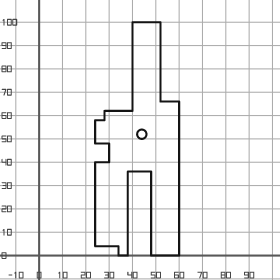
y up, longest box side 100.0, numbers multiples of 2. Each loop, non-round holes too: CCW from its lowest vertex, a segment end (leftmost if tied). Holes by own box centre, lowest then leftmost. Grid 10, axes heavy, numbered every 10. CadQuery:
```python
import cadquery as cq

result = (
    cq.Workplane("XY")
    .moveTo(34.0, 0.0)
    .lineTo(38.0, 0.0)
    .lineTo(38.0, 36.0)
    .lineTo(48.0, 36.0)
    .lineTo(48.0, 0.0)
    .lineTo(60.0, 0.0)
    .lineTo(60.0, 66.0)
    .lineTo(52.0, 66.0)
    .lineTo(52.0, 100.0)
    .lineTo(40.0, 100.0)
    .lineTo(40.0, 62.0)
    .lineTo(28.0, 62.0)
    .lineTo(28.0, 58.0)
    .lineTo(24.0, 58.0)
    .lineTo(24.0, 48.0)
    .lineTo(30.0, 48.0)
    .lineTo(30.0, 40.0)
    .lineTo(24.0, 40.0)
    .lineTo(24.0, 4.0)
    .lineTo(34.0, 4.0)
    .close()
    .moveTo(44.0, 52.0)
    .circle(2.0)
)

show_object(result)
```